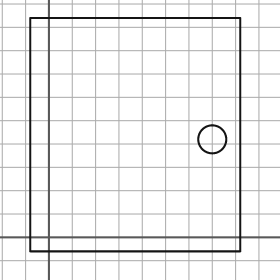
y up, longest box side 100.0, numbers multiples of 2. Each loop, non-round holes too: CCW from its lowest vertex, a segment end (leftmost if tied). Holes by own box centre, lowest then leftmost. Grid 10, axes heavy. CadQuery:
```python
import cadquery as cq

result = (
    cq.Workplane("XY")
    .moveTo(-8.0, -6.0)
    .lineTo(82.0, -6.0)
    .lineTo(82.0, 94.0)
    .lineTo(-8.0, 94.0)
    .close()
    .moveTo(70.0, 42.0)
    .circle(6.0)
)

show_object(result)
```